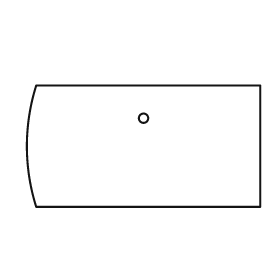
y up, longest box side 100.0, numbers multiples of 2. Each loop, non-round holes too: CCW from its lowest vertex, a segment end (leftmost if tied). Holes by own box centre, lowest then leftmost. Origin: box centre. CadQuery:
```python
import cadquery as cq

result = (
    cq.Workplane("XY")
    .moveTo(-46.0, -26.0)
    .lineTo(50.0, -26.0)
    .lineTo(50.0, 26.0)
    .lineTo(-46.0, 26.0)
    .threePointArc((-50.0, 0.0), (-46.0, -26.0))
    .close()
    .moveTo(0.0, 12.0)
    .circle(2.0)
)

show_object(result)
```